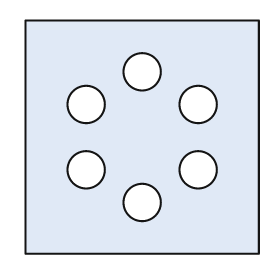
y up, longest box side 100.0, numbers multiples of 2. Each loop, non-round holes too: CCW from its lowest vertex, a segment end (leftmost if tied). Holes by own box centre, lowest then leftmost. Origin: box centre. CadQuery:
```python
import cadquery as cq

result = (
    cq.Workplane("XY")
    .moveTo(-50.0, -50.0)
    .lineTo(50.0, -50.0)
    .lineTo(50.0, 50.0)
    .lineTo(-50.0, 50.0)
    .close()
    .moveTo(0.0, -28.0)
    .circle(8.0)
    .moveTo(-24.0, -14.0)
    .circle(8.0)
    .moveTo(24.0, -14.0)
    .circle(8.0)
    .moveTo(-24.0, 14.0)
    .circle(8.0)
    .moveTo(24.0, 14.0)
    .circle(8.0)
    .moveTo(0.0, 28.0)
    .circle(8.0)
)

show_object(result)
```